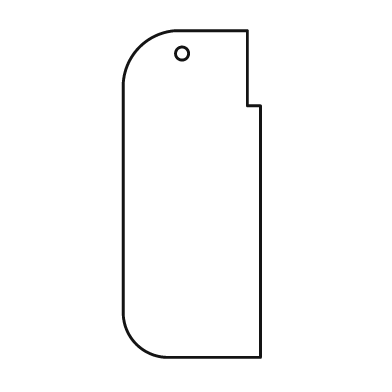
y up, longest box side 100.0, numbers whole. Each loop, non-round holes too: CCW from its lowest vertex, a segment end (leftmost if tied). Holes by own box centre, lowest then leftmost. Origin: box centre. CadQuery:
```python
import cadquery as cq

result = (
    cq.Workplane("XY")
    .moveTo(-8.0, -50.0)
    .lineTo(21.0, -50.0)
    .lineTo(21.0, 27.0)
    .lineTo(17.0, 27.0)
    .lineTo(17.0, 50.0)
    .lineTo(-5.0, 50.0)
    .threePointArc((-16.0, 45.0), (-21.0, 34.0))
    .lineTo(-21.0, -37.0)
    .threePointArc((-17.0, -46.0), (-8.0, -50.0))
    .close()
    .moveTo(-3.0, 43.0)
    .circle(2.0)
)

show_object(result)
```